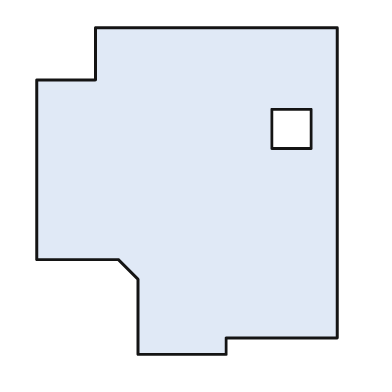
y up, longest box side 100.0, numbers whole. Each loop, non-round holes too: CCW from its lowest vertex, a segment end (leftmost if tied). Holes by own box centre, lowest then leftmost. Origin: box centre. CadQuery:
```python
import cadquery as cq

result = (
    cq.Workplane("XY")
    .moveTo(-15.0, -50.0)
    .lineTo(12.0, -50.0)
    .lineTo(12.0, -45.0)
    .lineTo(46.0, -45.0)
    .lineTo(46.0, 50.0)
    .lineTo(-28.0, 50.0)
    .lineTo(-28.0, 34.0)
    .lineTo(-46.0, 34.0)
    .lineTo(-46.0, -21.0)
    .lineTo(-21.0, -21.0)
    .lineTo(-15.0, -27.0)
    .close()
    .moveTo(26.0, 13.0)
    .lineTo(38.0, 13.0)
    .lineTo(38.0, 25.0)
    .lineTo(26.0, 25.0)
    .close()
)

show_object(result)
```